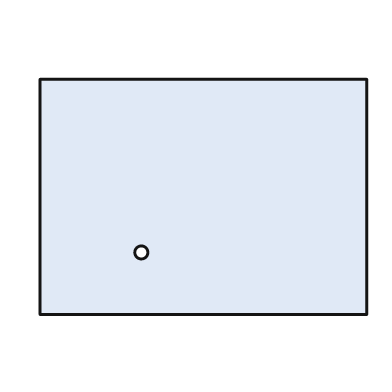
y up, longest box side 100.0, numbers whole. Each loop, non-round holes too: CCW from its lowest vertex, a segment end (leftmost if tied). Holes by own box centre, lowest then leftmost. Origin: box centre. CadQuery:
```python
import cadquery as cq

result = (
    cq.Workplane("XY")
    .moveTo(-50.0, -36.0)
    .lineTo(50.0, -36.0)
    .lineTo(50.0, 36.0)
    .lineTo(-50.0, 36.0)
    .close()
    .moveTo(-19.0, -17.0)
    .circle(2.0)
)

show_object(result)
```